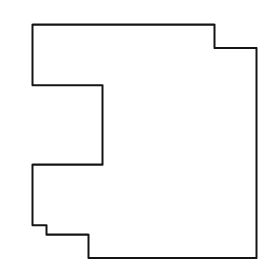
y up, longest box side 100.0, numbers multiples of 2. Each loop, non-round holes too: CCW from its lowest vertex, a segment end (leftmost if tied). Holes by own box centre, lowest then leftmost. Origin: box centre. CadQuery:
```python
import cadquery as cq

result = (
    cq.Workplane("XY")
    .moveTo(-24.0, -50.0)
    .lineTo(48.0, -50.0)
    .lineTo(48.0, 40.0)
    .lineTo(30.0, 40.0)
    .lineTo(30.0, 50.0)
    .lineTo(-48.0, 50.0)
    .lineTo(-48.0, 24.0)
    .lineTo(-18.0, 24.0)
    .lineTo(-18.0, -10.0)
    .lineTo(-48.0, -10.0)
    .lineTo(-48.0, -36.0)
    .lineTo(-42.0, -36.0)
    .lineTo(-42.0, -40.0)
    .lineTo(-24.0, -40.0)
    .close()
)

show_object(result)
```